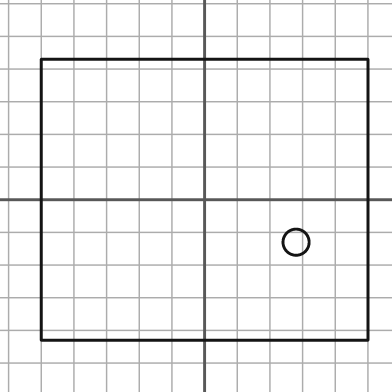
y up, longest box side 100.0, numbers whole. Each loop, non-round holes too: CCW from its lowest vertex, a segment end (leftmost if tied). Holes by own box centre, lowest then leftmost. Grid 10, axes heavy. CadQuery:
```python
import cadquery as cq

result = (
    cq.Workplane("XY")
    .moveTo(-50.0, -43.0)
    .lineTo(50.0, -43.0)
    .lineTo(50.0, 43.0)
    .lineTo(-50.0, 43.0)
    .close()
    .moveTo(28.0, -13.0)
    .circle(4.0)
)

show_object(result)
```